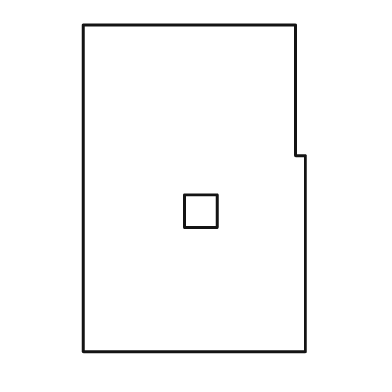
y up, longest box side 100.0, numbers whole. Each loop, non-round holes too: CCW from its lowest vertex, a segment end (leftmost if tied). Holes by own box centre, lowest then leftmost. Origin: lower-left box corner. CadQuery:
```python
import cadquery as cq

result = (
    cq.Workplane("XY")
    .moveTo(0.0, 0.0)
    .lineTo(68.0, 0.0)
    .lineTo(68.0, 60.0)
    .lineTo(65.0, 60.0)
    .lineTo(65.0, 100.0)
    .lineTo(0.0, 100.0)
    .close()
    .moveTo(31.0, 38.0)
    .lineTo(41.0, 38.0)
    .lineTo(41.0, 48.0)
    .lineTo(31.0, 48.0)
    .close()
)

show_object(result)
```